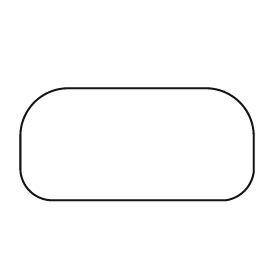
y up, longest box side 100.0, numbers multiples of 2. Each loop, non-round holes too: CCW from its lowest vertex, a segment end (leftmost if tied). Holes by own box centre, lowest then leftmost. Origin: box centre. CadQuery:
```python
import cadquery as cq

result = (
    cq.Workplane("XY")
    .moveTo(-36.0, -24.0)
    .lineTo(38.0, -24.0)
    .threePointArc((46.0, -20.0), (50.0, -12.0))
    .lineTo(50.0, 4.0)
    .threePointArc((44.0, 18.0), (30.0, 24.0))
    .lineTo(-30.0, 24.0)
    .threePointArc((-44.0, 18.0), (-50.0, 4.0))
    .lineTo(-50.0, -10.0)
    .threePointArc((-46.0, -20.0), (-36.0, -24.0))
    .close()
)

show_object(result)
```